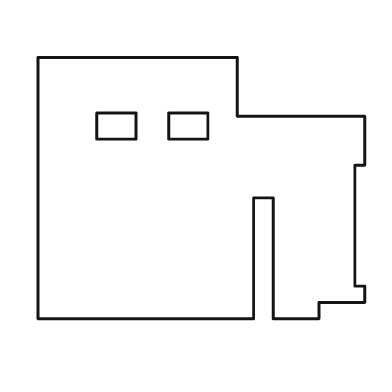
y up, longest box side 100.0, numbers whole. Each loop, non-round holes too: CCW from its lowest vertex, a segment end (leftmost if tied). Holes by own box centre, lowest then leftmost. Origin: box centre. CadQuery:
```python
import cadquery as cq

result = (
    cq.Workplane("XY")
    .moveTo(-50.0, -40.0)
    .lineTo(16.0, -40.0)
    .lineTo(16.0, -3.0)
    .lineTo(22.0, -3.0)
    .lineTo(22.0, -40.0)
    .lineTo(36.0, -40.0)
    .lineTo(36.0, -35.0)
    .lineTo(50.0, -35.0)
    .lineTo(50.0, -30.0)
    .lineTo(47.0, -30.0)
    .lineTo(47.0, 7.0)
    .lineTo(50.0, 7.0)
    .lineTo(50.0, 22.0)
    .lineTo(11.0, 22.0)
    .lineTo(11.0, 40.0)
    .lineTo(-50.0, 40.0)
    .close()
    .moveTo(-32.0, 15.0)
    .lineTo(-20.0, 15.0)
    .lineTo(-20.0, 23.0)
    .lineTo(-32.0, 23.0)
    .close()
    .moveTo(-10.0, 15.0)
    .lineTo(2.0, 15.0)
    .lineTo(2.0, 23.0)
    .lineTo(-10.0, 23.0)
    .close()
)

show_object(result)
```